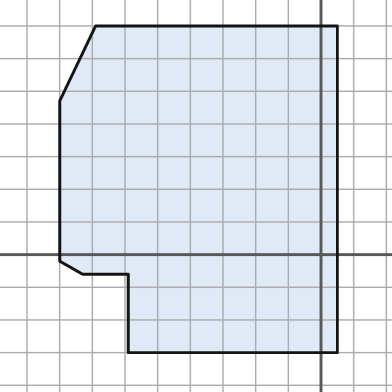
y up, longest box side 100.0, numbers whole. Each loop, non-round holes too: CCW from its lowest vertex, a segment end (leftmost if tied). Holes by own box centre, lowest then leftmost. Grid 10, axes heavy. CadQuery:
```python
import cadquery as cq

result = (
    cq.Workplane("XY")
    .moveTo(-59.0, -30.0)
    .lineTo(5.0, -30.0)
    .lineTo(5.0, 70.0)
    .lineTo(-69.0, 70.0)
    .lineTo(-80.0, 47.0)
    .lineTo(-80.0, -2.0)
    .lineTo(-73.0, -6.0)
    .lineTo(-59.0, -6.0)
    .close()
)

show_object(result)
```